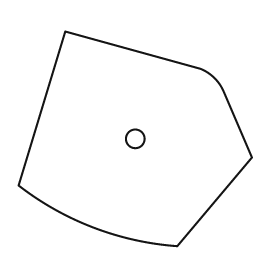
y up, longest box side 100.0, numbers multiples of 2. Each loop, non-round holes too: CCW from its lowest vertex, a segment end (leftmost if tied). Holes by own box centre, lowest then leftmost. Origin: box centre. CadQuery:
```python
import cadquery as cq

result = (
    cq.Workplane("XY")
    .moveTo(18.0, -46.0)
    .lineTo(50.0, -8.0)
    .lineTo(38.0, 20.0)
    .threePointArc((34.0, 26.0), (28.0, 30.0))
    .lineTo(-30.0, 46.0)
    .lineTo(-50.0, -20.0)
    .threePointArc((-18.0, -38.0), (18.0, -46.0))
    .close()
    .moveTo(0.0, 0.0)
    .circle(4.0)
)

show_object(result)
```